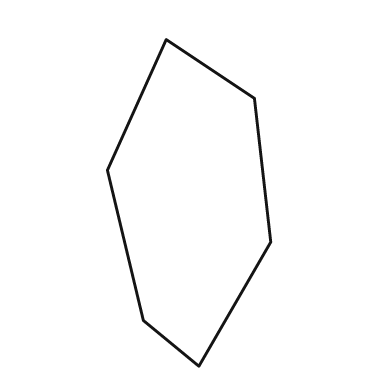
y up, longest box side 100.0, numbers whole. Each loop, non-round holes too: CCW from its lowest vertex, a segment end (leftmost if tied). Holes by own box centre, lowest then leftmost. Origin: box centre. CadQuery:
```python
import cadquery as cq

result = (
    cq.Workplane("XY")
    .moveTo(3.0, -50.0)
    .lineTo(25.0, -12.0)
    .lineTo(20.0, 32.0)
    .lineTo(-7.0, 50.0)
    .lineTo(-25.0, 10.0)
    .lineTo(-14.0, -36.0)
    .close()
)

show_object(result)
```